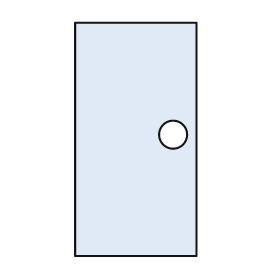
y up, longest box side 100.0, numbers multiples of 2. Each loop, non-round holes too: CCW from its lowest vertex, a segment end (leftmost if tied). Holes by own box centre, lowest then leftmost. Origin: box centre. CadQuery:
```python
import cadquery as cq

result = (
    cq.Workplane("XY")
    .moveTo(-26.0, -50.0)
    .lineTo(26.0, -50.0)
    .lineTo(26.0, 50.0)
    .lineTo(-26.0, 50.0)
    .close()
    .moveTo(16.0, 2.0)
    .circle(6.0)
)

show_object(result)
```